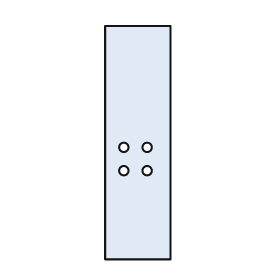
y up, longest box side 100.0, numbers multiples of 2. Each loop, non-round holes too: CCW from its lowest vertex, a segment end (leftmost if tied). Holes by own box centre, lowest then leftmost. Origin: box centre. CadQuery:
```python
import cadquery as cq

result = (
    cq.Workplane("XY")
    .moveTo(-14.0, -50.0)
    .lineTo(14.0, -50.0)
    .lineTo(14.0, 50.0)
    .lineTo(-14.0, 50.0)
    .close()
    .moveTo(-6.0, -12.0)
    .circle(2.0)
    .moveTo(4.0, -12.0)
    .circle(2.0)
    .moveTo(-6.0, -2.0)
    .circle(2.0)
    .moveTo(4.0, -2.0)
    .circle(2.0)
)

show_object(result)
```